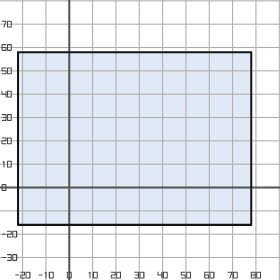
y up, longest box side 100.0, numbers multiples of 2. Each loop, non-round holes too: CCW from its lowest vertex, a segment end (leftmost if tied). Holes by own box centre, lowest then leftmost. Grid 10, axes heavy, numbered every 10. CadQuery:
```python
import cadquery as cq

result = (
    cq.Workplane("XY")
    .moveTo(-22.0, -16.0)
    .lineTo(78.0, -16.0)
    .lineTo(78.0, 58.0)
    .lineTo(-22.0, 58.0)
    .close()
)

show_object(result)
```